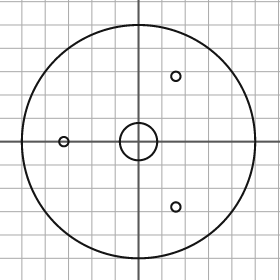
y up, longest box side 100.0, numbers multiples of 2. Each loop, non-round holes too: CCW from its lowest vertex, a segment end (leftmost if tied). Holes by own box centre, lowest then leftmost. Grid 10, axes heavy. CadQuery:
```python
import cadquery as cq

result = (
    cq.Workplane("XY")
    .moveTo(0.0, 0.0)
    .circle(50.0)
    .moveTo(16.0, -28.0)
    .circle(2.0)
    .moveTo(-32.0, 0.0)
    .circle(2.0)
    .moveTo(0.0, 0.0)
    .circle(8.0)
    .moveTo(16.0, 28.0)
    .circle(2.0)
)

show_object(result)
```